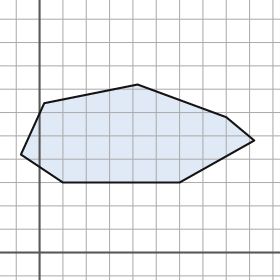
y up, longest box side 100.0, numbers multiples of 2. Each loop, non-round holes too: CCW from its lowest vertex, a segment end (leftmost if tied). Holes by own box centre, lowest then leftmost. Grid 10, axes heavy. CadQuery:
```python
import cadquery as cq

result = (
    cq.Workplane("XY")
    .moveTo(10.0, 30.0)
    .lineTo(60.0, 30.0)
    .lineTo(92.0, 48.0)
    .lineTo(80.0, 58.0)
    .lineTo(42.0, 72.0)
    .lineTo(2.0, 64.0)
    .lineTo(-8.0, 42.0)
    .close()
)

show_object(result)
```